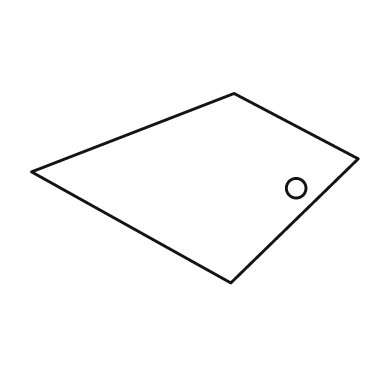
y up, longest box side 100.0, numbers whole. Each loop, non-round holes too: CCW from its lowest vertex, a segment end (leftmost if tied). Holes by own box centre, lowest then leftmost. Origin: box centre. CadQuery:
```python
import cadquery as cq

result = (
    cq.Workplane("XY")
    .moveTo(11.0, -29.0)
    .lineTo(50.0, 9.0)
    .lineTo(12.0, 29.0)
    .lineTo(-50.0, 5.0)
    .close()
    .moveTo(31.0, 0.0)
    .circle(3.0)
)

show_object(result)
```